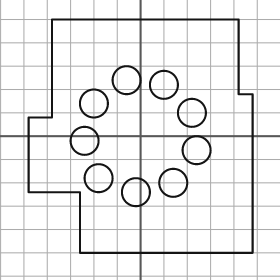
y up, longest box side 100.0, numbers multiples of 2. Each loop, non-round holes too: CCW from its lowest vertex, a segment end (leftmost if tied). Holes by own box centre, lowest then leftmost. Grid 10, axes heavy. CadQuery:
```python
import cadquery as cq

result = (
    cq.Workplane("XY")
    .moveTo(-26.0, -50.0)
    .lineTo(48.0, -50.0)
    .lineTo(48.0, 18.0)
    .lineTo(42.0, 18.0)
    .lineTo(42.0, 50.0)
    .lineTo(-38.0, 50.0)
    .lineTo(-38.0, 8.0)
    .lineTo(-48.0, 8.0)
    .lineTo(-48.0, -24.0)
    .lineTo(-26.0, -24.0)
    .close()
    .moveTo(-2.0, -24.0)
    .circle(6.0)
    .moveTo(14.0, -20.0)
    .circle(6.0)
    .moveTo(-18.0, -18.0)
    .circle(6.0)
    .moveTo(24.0, -6.0)
    .circle(6.0)
    .moveTo(-24.0, -2.0)
    .circle(6.0)
    .moveTo(22.0, 10.0)
    .circle(6.0)
    .moveTo(-20.0, 14.0)
    .circle(6.0)
    .moveTo(10.0, 22.0)
    .circle(6.0)
    .moveTo(-6.0, 24.0)
    .circle(6.0)
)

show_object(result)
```